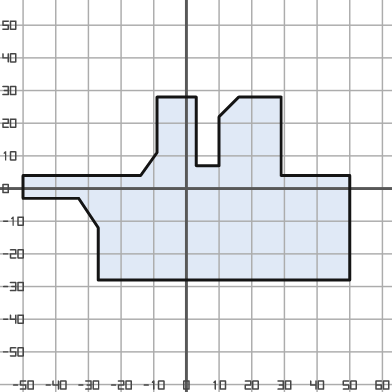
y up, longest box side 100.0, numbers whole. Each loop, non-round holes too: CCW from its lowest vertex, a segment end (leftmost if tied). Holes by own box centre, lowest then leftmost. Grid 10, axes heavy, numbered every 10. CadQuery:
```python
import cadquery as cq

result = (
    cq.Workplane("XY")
    .moveTo(-27.0, -28.0)
    .lineTo(50.0, -28.0)
    .lineTo(50.0, 4.0)
    .lineTo(29.0, 4.0)
    .lineTo(29.0, 28.0)
    .lineTo(16.0, 28.0)
    .lineTo(10.0, 22.0)
    .lineTo(10.0, 7.0)
    .lineTo(3.0, 7.0)
    .lineTo(3.0, 28.0)
    .lineTo(-9.0, 28.0)
    .lineTo(-9.0, 11.0)
    .lineTo(-14.0, 4.0)
    .lineTo(-50.0, 4.0)
    .lineTo(-50.0, -3.0)
    .lineTo(-33.0, -3.0)
    .lineTo(-27.0, -12.0)
    .close()
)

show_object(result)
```